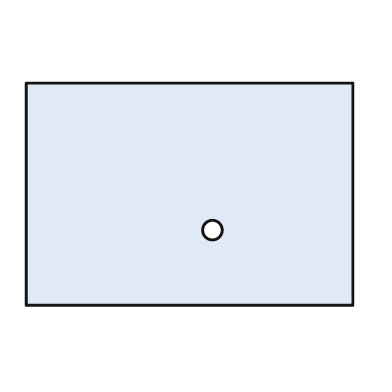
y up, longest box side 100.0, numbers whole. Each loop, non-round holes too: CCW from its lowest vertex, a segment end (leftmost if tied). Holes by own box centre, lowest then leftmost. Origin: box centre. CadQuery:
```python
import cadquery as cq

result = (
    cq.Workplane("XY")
    .moveTo(-50.0, -34.0)
    .lineTo(50.0, -34.0)
    .lineTo(50.0, 34.0)
    .lineTo(-50.0, 34.0)
    .close()
    .moveTo(7.0, -11.0)
    .circle(3.0)
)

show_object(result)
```